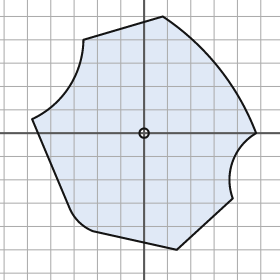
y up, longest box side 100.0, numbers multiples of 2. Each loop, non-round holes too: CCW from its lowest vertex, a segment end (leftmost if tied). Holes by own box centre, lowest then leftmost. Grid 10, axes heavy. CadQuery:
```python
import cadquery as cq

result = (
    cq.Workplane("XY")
    .moveTo(14.0, -50.0)
    .lineTo(38.0, -28.0)
    .threePointArc((38.0, -12.0), (48.0, 0.0))
    .threePointArc((32.0, 28.0), (8.0, 50.0))
    .lineTo(-26.0, 40.0)
    .threePointArc((-32.0, 20.0), (-48.0, 6.0))
    .lineTo(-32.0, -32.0)
    .threePointArc((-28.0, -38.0), (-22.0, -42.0))
    .close()
    .moveTo(0.0, 0.0)
    .circle(2.0)
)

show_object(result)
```